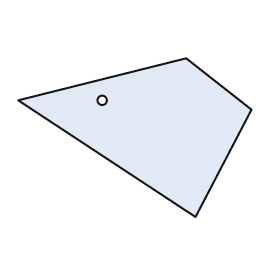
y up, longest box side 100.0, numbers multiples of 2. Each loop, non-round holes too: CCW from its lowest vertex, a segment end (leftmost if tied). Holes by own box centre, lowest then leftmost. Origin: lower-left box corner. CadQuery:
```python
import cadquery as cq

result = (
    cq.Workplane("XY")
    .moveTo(76.0, 0.0)
    .lineTo(100.0, 46.0)
    .lineTo(72.0, 68.0)
    .lineTo(0.0, 50.0)
    .close()
    .moveTo(36.0, 50.0)
    .circle(2.0)
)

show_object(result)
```